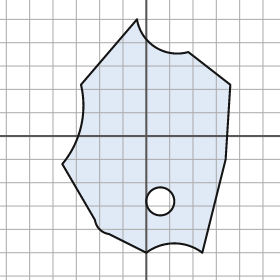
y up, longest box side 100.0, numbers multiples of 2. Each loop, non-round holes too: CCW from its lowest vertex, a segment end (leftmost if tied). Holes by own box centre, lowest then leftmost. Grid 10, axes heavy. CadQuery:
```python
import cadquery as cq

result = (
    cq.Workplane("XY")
    .moveTo(0.0, -50.0)
    .threePointArc((12.0, -46.0), (24.0, -50.0))
    .lineTo(34.0, -10.0)
    .lineTo(36.0, 22.0)
    .lineTo(18.0, 36.0)
    .threePointArc((4.0, 38.0), (-4.0, 50.0))
    .lineTo(-28.0, 22.0)
    .threePointArc((-28.0, 4.0), (-36.0, -12.0))
    .lineTo(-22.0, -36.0)
    .threePointArc((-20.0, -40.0), (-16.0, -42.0))
    .close()
    .moveTo(6.0, -28.0)
    .circle(6.0)
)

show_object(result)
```